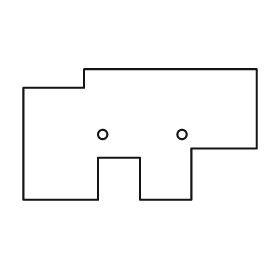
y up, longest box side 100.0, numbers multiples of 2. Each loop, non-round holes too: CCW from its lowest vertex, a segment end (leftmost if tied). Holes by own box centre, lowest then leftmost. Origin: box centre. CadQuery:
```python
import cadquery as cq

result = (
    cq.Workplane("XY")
    .moveTo(-50.0, -28.0)
    .lineTo(-18.0, -28.0)
    .lineTo(-18.0, -10.0)
    .lineTo(0.0, -10.0)
    .lineTo(0.0, -28.0)
    .lineTo(22.0, -28.0)
    .lineTo(22.0, -6.0)
    .lineTo(50.0, -6.0)
    .lineTo(50.0, 28.0)
    .lineTo(-24.0, 28.0)
    .lineTo(-24.0, 20.0)
    .lineTo(-50.0, 20.0)
    .close()
    .moveTo(-16.0, 0.0)
    .circle(2.0)
    .moveTo(18.0, 0.0)
    .circle(2.0)
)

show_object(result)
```